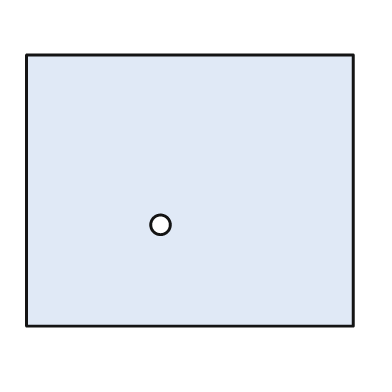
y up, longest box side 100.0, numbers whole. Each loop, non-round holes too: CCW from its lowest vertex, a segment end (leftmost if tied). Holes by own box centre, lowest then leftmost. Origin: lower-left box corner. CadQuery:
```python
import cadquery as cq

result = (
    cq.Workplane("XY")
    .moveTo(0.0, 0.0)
    .lineTo(100.0, 0.0)
    .lineTo(100.0, 83.0)
    .lineTo(0.0, 83.0)
    .close()
    .moveTo(41.0, 31.0)
    .circle(3.0)
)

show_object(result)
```